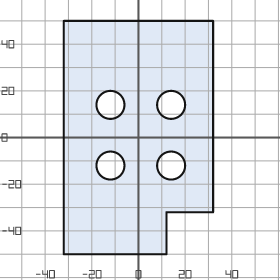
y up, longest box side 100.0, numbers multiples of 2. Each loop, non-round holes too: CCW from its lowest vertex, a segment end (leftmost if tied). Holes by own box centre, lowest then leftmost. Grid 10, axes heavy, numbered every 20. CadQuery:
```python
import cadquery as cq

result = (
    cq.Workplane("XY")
    .moveTo(-32.0, -50.0)
    .lineTo(12.0, -50.0)
    .lineTo(12.0, -32.0)
    .lineTo(32.0, -32.0)
    .lineTo(32.0, 50.0)
    .lineTo(-32.0, 50.0)
    .close()
    .moveTo(-12.0, -12.0)
    .circle(6.0)
    .moveTo(14.0, -12.0)
    .circle(6.0)
    .moveTo(-12.0, 14.0)
    .circle(6.0)
    .moveTo(14.0, 14.0)
    .circle(6.0)
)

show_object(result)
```